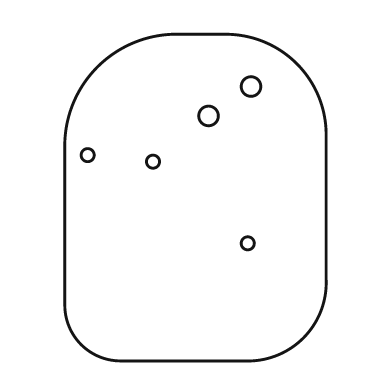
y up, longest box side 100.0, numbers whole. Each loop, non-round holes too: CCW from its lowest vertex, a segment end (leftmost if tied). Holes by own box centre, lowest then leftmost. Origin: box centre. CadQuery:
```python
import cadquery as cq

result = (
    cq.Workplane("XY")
    .moveTo(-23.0, -50.0)
    .lineTo(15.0, -50.0)
    .threePointArc((33.0, -43.0), (40.0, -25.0))
    .lineTo(40.0, 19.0)
    .threePointArc((31.0, 41.0), (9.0, 50.0))
    .lineTo(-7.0, 50.0)
    .threePointArc((-30.0, 40.0), (-40.0, 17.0))
    .lineTo(-40.0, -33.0)
    .threePointArc((-35.0, -45.0), (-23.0, -50.0))
    .close()
    .moveTo(16.0, -14.0)
    .circle(2.0)
    .moveTo(-13.0, 11.0)
    .circle(2.0)
    .moveTo(-33.0, 13.0)
    .circle(2.0)
    .moveTo(4.0, 25.0)
    .circle(3.0)
    .moveTo(17.0, 34.0)
    .circle(3.0)
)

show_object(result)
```